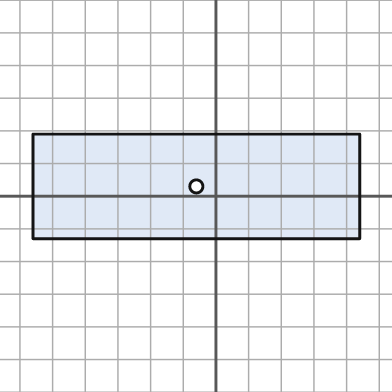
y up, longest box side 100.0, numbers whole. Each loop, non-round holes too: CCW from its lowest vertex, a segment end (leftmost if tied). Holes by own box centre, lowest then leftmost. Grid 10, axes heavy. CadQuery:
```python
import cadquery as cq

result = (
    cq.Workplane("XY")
    .moveTo(-56.0, -13.0)
    .lineTo(44.0, -13.0)
    .lineTo(44.0, 19.0)
    .lineTo(-56.0, 19.0)
    .close()
    .moveTo(-6.0, 3.0)
    .circle(2.0)
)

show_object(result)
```